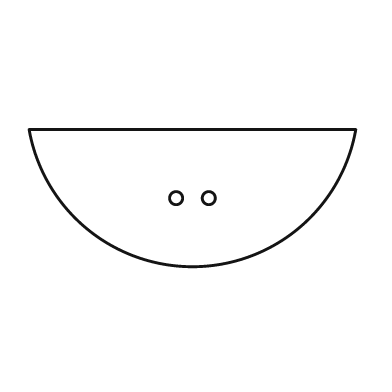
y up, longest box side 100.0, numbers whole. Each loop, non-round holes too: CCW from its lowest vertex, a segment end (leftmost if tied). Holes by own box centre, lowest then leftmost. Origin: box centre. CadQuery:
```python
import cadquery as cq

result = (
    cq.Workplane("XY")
    .moveTo(-50.0, 21.0)
    .threePointArc((0.0, -21.0), (50.0, 21.0))
    .close()
    .moveTo(-5.0, 0.0)
    .circle(2.0)
    .moveTo(5.0, 0.0)
    .circle(2.0)
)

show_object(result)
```